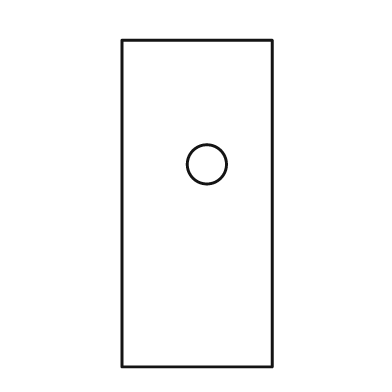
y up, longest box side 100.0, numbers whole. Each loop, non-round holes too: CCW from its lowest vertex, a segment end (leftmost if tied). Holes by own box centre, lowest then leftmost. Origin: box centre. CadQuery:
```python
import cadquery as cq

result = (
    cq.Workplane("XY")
    .moveTo(-23.0, -50.0)
    .lineTo(23.0, -50.0)
    .lineTo(23.0, 50.0)
    .lineTo(-23.0, 50.0)
    .close()
    .moveTo(3.0, 12.0)
    .circle(6.0)
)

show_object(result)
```